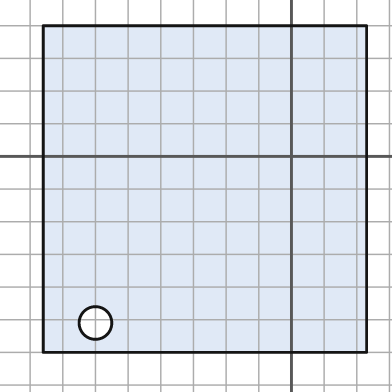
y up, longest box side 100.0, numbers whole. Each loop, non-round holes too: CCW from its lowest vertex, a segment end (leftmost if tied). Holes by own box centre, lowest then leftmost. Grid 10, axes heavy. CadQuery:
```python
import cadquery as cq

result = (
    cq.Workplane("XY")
    .moveTo(-76.0, -60.0)
    .lineTo(23.0, -60.0)
    .lineTo(23.0, 40.0)
    .lineTo(-76.0, 40.0)
    .close()
    .moveTo(-60.0, -51.0)
    .circle(5.0)
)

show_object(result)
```